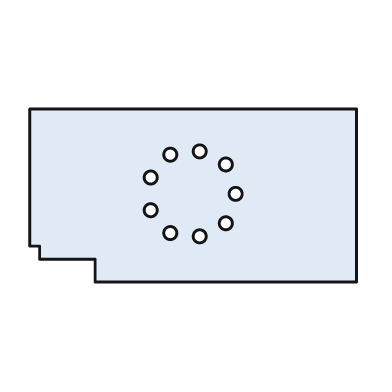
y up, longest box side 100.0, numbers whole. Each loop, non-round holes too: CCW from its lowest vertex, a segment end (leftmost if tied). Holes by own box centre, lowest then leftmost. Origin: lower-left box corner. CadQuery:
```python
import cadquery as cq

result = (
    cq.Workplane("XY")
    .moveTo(20.0, 0.0)
    .lineTo(100.0, 0.0)
    .lineTo(100.0, 53.0)
    .lineTo(0.0, 53.0)
    .lineTo(0.0, 11.0)
    .lineTo(3.0, 11.0)
    .lineTo(3.0, 7.0)
    .lineTo(20.0, 7.0)
    .close()
    .moveTo(52.0, 14.0)
    .circle(2.0)
    .moveTo(43.0, 15.0)
    .circle(2.0)
    .moveTo(60.0, 18.0)
    .circle(2.0)
    .moveTo(37.0, 22.0)
    .circle(2.0)
    .moveTo(63.0, 27.0)
    .circle(2.0)
    .moveTo(37.0, 32.0)
    .circle(2.0)
    .moveTo(60.0, 36.0)
    .circle(2.0)
    .moveTo(43.0, 39.0)
    .circle(2.0)
    .moveTo(52.0, 40.0)
    .circle(2.0)
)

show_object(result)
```